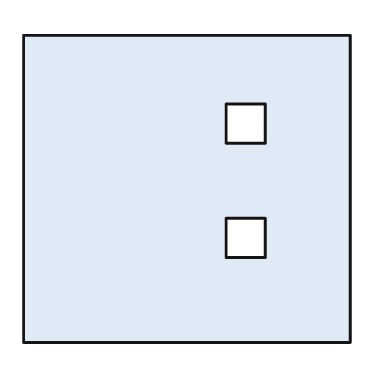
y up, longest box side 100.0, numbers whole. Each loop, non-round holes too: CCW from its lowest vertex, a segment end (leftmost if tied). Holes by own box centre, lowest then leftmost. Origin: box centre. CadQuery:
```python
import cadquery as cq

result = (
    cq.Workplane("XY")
    .moveTo(-50.0, -47.0)
    .lineTo(50.0, -47.0)
    .lineTo(50.0, 47.0)
    .lineTo(-50.0, 47.0)
    .close()
    .moveTo(12.0, -21.0)
    .lineTo(24.0, -21.0)
    .lineTo(24.0, -9.0)
    .lineTo(12.0, -9.0)
    .close()
    .moveTo(12.0, 14.0)
    .lineTo(24.0, 14.0)
    .lineTo(24.0, 26.0)
    .lineTo(12.0, 26.0)
    .close()
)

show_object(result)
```